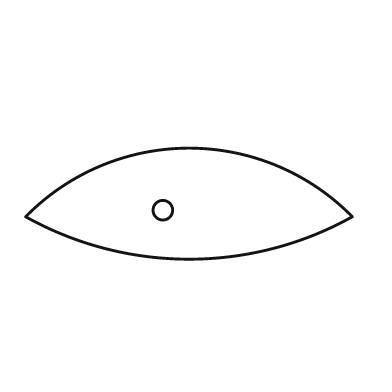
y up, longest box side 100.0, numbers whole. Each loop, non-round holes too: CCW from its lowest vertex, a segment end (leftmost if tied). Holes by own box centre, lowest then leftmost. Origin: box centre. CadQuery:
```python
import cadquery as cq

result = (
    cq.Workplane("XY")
    .moveTo(-50.0, -4.0)
    .threePointArc((0.0, -17.0), (50.0, -4.0))
    .threePointArc((0.0, 17.0), (-50.0, -4.0))
    .close()
    .moveTo(-8.0, -2.0)
    .circle(3.0)
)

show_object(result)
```